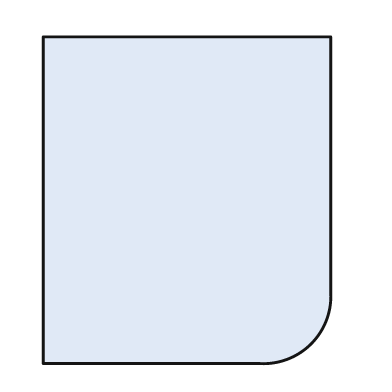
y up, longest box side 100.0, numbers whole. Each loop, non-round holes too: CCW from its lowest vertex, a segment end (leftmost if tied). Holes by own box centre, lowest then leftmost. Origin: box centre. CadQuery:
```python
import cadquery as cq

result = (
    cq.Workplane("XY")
    .moveTo(-44.0, -50.0)
    .lineTo(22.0, -50.0)
    .threePointArc((38.0, -44.0), (44.0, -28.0))
    .lineTo(44.0, 50.0)
    .lineTo(-44.0, 50.0)
    .close()
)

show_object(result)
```